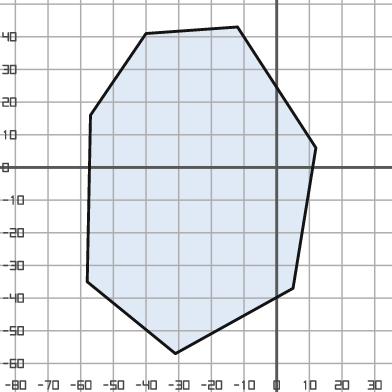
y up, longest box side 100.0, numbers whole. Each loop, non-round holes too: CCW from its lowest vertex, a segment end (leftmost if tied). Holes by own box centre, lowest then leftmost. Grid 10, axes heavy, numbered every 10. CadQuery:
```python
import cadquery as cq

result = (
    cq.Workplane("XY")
    .moveTo(-31.0, -57.0)
    .lineTo(5.0, -37.0)
    .lineTo(12.0, 6.0)
    .lineTo(-12.0, 43.0)
    .lineTo(-40.0, 41.0)
    .lineTo(-57.0, 16.0)
    .lineTo(-58.0, -35.0)
    .close()
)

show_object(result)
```